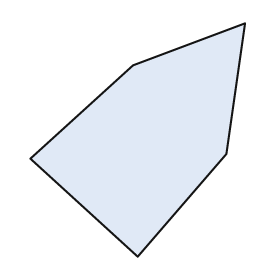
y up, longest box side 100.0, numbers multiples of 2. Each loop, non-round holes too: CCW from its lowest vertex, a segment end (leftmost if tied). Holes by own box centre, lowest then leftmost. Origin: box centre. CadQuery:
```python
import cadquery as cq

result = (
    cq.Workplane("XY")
    .moveTo(0.0, -50.0)
    .lineTo(38.0, -6.0)
    .lineTo(46.0, 50.0)
    .lineTo(-2.0, 32.0)
    .lineTo(-46.0, -8.0)
    .close()
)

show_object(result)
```